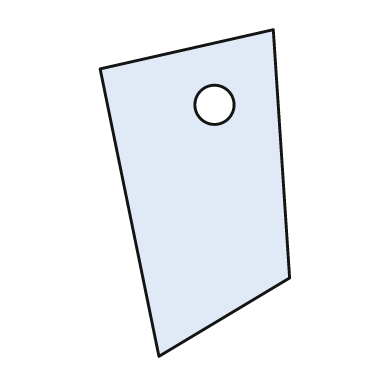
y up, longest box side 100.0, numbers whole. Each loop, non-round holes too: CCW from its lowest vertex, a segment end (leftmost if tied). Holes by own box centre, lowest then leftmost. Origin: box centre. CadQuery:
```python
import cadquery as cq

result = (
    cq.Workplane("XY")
    .moveTo(-11.0, -50.0)
    .lineTo(29.0, -26.0)
    .lineTo(24.0, 50.0)
    .lineTo(-29.0, 38.0)
    .close()
    .moveTo(6.0, 27.0)
    .circle(6.0)
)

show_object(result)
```